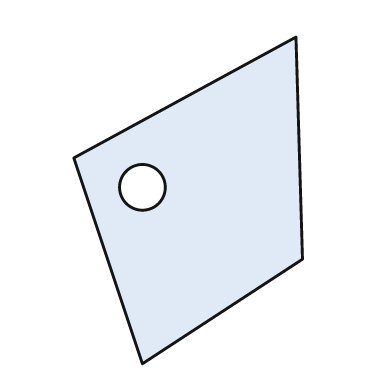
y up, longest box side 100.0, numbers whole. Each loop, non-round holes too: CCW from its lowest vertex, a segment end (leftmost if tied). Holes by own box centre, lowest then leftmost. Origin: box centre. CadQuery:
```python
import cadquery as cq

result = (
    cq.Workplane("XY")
    .moveTo(-14.0, -50.0)
    .lineTo(35.0, -18.0)
    .lineTo(33.0, 50.0)
    .lineTo(-35.0, 13.0)
    .close()
    .moveTo(-14.0, 4.0)
    .circle(7.0)
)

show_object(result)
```